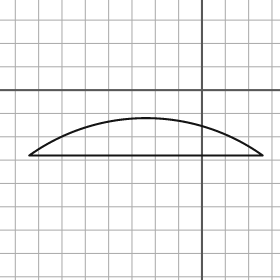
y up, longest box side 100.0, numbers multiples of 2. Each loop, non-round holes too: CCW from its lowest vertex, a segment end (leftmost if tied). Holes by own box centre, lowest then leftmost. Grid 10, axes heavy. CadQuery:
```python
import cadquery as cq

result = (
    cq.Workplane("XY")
    .moveTo(-74.0, -28.0)
    .lineTo(26.0, -28.0)
    .threePointArc((-24.0, -12.0), (-74.0, -28.0))
    .close()
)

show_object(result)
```